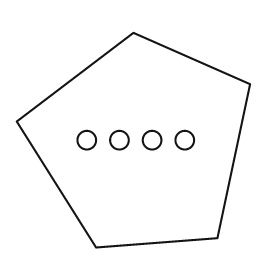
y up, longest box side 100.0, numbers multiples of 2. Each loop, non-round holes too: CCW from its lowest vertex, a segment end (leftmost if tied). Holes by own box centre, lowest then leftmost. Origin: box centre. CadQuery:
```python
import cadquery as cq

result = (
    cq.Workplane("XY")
    .moveTo(-16.0, -46.0)
    .lineTo(36.0, -42.0)
    .lineTo(50.0, 24.0)
    .lineTo(0.0, 46.0)
    .lineTo(-50.0, 8.0)
    .close()
    .moveTo(-20.0, 0.0)
    .circle(4.0)
    .moveTo(-6.0, 0.0)
    .circle(4.0)
    .moveTo(8.0, 0.0)
    .circle(4.0)
    .moveTo(22.0, 0.0)
    .circle(4.0)
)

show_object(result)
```